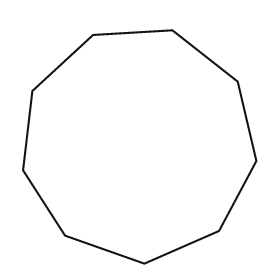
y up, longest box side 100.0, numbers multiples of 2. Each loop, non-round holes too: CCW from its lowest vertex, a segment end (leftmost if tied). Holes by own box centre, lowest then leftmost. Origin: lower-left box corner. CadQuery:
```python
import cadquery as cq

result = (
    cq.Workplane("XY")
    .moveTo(52.0, 0.0)
    .lineTo(84.0, 14.0)
    .lineTo(100.0, 44.0)
    .lineTo(92.0, 78.0)
    .lineTo(64.0, 100.0)
    .lineTo(30.0, 98.0)
    .lineTo(4.0, 74.0)
    .lineTo(0.0, 40.0)
    .lineTo(18.0, 12.0)
    .close()
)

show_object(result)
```